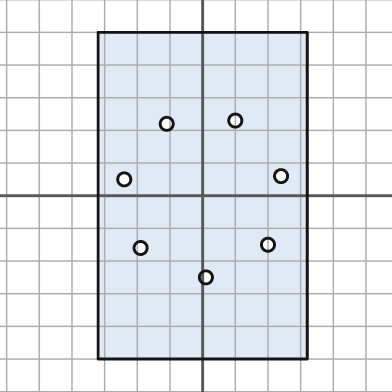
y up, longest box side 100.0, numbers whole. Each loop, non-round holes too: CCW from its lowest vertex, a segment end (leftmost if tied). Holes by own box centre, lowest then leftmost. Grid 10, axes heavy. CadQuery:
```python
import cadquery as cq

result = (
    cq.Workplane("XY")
    .moveTo(-32.0, -50.0)
    .lineTo(32.0, -50.0)
    .lineTo(32.0, 50.0)
    .lineTo(-32.0, 50.0)
    .close()
    .moveTo(1.0, -25.0)
    .circle(2.0)
    .moveTo(-19.0, -16.0)
    .circle(2.0)
    .moveTo(20.0, -15.0)
    .circle(2.0)
    .moveTo(-24.0, 5.0)
    .circle(2.0)
    .moveTo(24.0, 6.0)
    .circle(2.0)
    .moveTo(-11.0, 22.0)
    .circle(2.0)
    .moveTo(10.0, 23.0)
    .circle(2.0)
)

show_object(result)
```